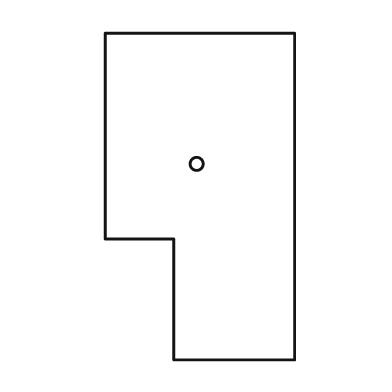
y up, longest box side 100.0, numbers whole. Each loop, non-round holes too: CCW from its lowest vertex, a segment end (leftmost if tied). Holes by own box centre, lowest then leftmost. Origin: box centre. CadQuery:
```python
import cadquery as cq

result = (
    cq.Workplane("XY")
    .moveTo(-8.0, -50.0)
    .lineTo(29.0, -50.0)
    .lineTo(29.0, 50.0)
    .lineTo(-29.0, 50.0)
    .lineTo(-29.0, -13.0)
    .lineTo(-8.0, -13.0)
    .close()
    .moveTo(-1.0, 10.0)
    .circle(2.0)
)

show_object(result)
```